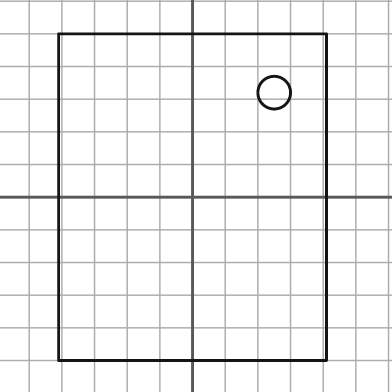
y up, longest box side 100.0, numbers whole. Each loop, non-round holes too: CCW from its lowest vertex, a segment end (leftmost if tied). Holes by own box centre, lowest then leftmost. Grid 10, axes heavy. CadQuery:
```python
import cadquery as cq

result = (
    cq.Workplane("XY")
    .moveTo(-41.0, -50.0)
    .lineTo(41.0, -50.0)
    .lineTo(41.0, 50.0)
    .lineTo(-41.0, 50.0)
    .close()
    .moveTo(25.0, 32.0)
    .circle(5.0)
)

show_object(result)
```